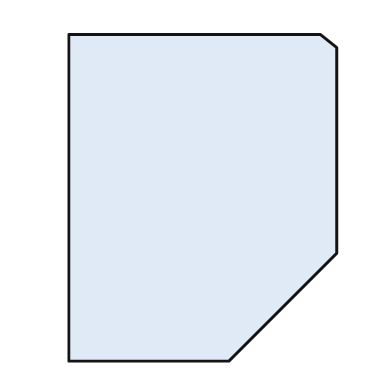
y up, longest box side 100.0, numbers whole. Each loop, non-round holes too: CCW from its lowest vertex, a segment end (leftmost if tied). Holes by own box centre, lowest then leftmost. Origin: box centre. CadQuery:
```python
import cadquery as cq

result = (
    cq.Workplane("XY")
    .moveTo(-41.0, -50.0)
    .lineTo(8.0, -50.0)
    .lineTo(41.0, -17.0)
    .lineTo(41.0, 46.0)
    .lineTo(36.0, 50.0)
    .lineTo(-41.0, 50.0)
    .close()
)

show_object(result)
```